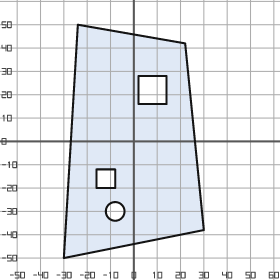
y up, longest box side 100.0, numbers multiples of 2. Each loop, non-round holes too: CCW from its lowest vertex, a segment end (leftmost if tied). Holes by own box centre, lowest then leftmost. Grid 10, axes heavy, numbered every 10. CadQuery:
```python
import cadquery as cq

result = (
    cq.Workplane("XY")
    .moveTo(-30.0, -50.0)
    .lineTo(30.0, -38.0)
    .lineTo(22.0, 42.0)
    .lineTo(-24.0, 50.0)
    .close()
    .moveTo(-8.0, -30.0)
    .circle(4.0)
    .moveTo(-16.0, -20.0)
    .lineTo(-8.0, -20.0)
    .lineTo(-8.0, -12.0)
    .lineTo(-16.0, -12.0)
    .close()
    .moveTo(2.0, 16.0)
    .lineTo(14.0, 16.0)
    .lineTo(14.0, 28.0)
    .lineTo(2.0, 28.0)
    .close()
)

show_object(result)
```